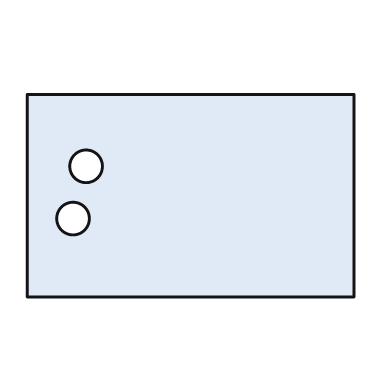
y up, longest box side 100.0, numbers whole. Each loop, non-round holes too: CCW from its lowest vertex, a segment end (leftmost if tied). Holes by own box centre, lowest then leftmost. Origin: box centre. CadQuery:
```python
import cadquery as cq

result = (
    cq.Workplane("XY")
    .moveTo(-50.0, -31.0)
    .lineTo(50.0, -31.0)
    .lineTo(50.0, 31.0)
    .lineTo(-50.0, 31.0)
    .close()
    .moveTo(-36.0, -7.0)
    .circle(5.0)
    .moveTo(-32.0, 9.0)
    .circle(5.0)
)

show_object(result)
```